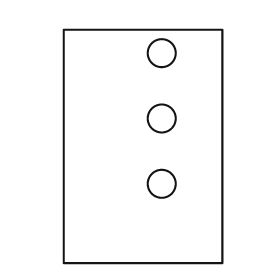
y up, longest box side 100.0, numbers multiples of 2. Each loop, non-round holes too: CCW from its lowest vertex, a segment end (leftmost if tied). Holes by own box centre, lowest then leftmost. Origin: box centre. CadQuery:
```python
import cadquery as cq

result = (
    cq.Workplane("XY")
    .moveTo(-34.0, -50.0)
    .lineTo(34.0, -50.0)
    .lineTo(34.0, 50.0)
    .lineTo(-34.0, 50.0)
    .close()
    .moveTo(8.0, -16.0)
    .circle(6.0)
    .moveTo(8.0, 12.0)
    .circle(6.0)
    .moveTo(8.0, 40.0)
    .circle(6.0)
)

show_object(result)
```